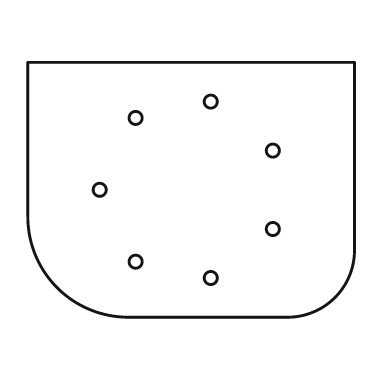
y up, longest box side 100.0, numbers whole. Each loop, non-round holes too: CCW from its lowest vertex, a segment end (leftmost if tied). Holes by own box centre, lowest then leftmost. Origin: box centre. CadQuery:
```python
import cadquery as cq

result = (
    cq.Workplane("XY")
    .moveTo(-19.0, -39.0)
    .lineTo(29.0, -39.0)
    .threePointArc((44.0, -33.0), (50.0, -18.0))
    .lineTo(50.0, 39.0)
    .lineTo(-50.0, 39.0)
    .lineTo(-50.0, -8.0)
    .threePointArc((-41.0, -30.0), (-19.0, -39.0))
    .close()
    .moveTo(6.0, -27.0)
    .circle(2.0)
    .moveTo(-17.0, -22.0)
    .circle(2.0)
    .moveTo(25.0, -12.0)
    .circle(2.0)
    .moveTo(-28.0, 0.0)
    .circle(2.0)
    .moveTo(25.0, 12.0)
    .circle(2.0)
    .moveTo(-17.0, 22.0)
    .circle(2.0)
    .moveTo(6.0, 27.0)
    .circle(2.0)
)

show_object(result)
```